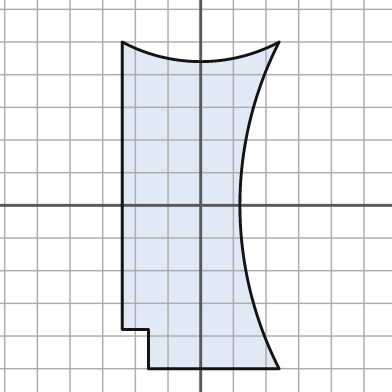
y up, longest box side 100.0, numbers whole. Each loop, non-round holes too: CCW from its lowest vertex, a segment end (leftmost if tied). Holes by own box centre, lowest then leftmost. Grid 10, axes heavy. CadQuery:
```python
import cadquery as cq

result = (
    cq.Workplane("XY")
    .moveTo(-16.0, -50.0)
    .lineTo(24.0, -50.0)
    .threePointArc((12.0, 0.0), (24.0, 50.0))
    .threePointArc((0.0, 44.0), (-24.0, 50.0))
    .lineTo(-24.0, -38.0)
    .lineTo(-16.0, -38.0)
    .close()
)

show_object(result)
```